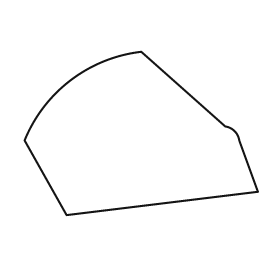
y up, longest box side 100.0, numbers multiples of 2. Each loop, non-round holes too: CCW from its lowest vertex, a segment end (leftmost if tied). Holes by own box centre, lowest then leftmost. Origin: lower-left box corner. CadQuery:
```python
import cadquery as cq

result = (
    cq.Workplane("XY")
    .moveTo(18.0, 0.0)
    .lineTo(100.0, 10.0)
    .lineTo(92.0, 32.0)
    .threePointArc((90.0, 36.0), (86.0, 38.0))
    .lineTo(50.0, 70.0)
    .threePointArc((20.0, 58.0), (0.0, 32.0))
    .close()
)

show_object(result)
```